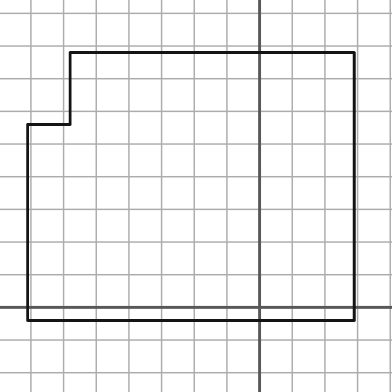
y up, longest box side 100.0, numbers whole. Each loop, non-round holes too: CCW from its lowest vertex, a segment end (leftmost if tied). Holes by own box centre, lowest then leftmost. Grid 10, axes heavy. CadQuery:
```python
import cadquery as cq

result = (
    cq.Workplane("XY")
    .moveTo(-71.0, -4.0)
    .lineTo(29.0, -4.0)
    .lineTo(29.0, 78.0)
    .lineTo(-58.0, 78.0)
    .lineTo(-58.0, 56.0)
    .lineTo(-71.0, 56.0)
    .close()
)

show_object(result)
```